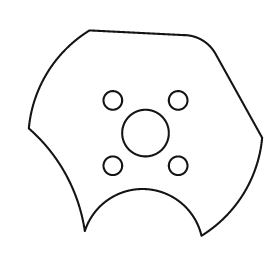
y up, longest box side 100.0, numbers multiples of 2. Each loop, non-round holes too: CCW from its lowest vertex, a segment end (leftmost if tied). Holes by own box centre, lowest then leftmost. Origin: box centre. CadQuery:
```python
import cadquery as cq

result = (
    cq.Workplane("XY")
    .moveTo(24.0, -44.0)
    .threePointArc((42.0, -26.0), (50.0, -2.0))
    .lineTo(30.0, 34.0)
    .threePointArc((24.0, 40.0), (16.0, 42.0))
    .lineTo(-24.0, 44.0)
    .threePointArc((-42.0, 26.0), (-50.0, 2.0))
    .threePointArc((-34.0, -18.0), (-26.0, -42.0))
    .threePointArc((0.0, -24.0), (24.0, -44.0))
    .close()
    .moveTo(-14.0, -14.0)
    .circle(4.0)
    .moveTo(14.0, -14.0)
    .circle(4.0)
    .moveTo(0.0, 0.0)
    .circle(10.0)
    .moveTo(-14.0, 14.0)
    .circle(4.0)
    .moveTo(14.0, 14.0)
    .circle(4.0)
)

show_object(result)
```